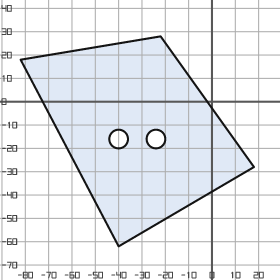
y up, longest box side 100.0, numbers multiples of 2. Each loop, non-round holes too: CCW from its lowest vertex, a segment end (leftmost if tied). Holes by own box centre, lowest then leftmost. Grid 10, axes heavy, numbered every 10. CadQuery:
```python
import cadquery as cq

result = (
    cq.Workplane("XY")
    .moveTo(-40.0, -62.0)
    .lineTo(18.0, -28.0)
    .lineTo(-22.0, 28.0)
    .lineTo(-82.0, 18.0)
    .close()
    .moveTo(-40.0, -16.0)
    .circle(4.0)
    .moveTo(-24.0, -16.0)
    .circle(4.0)
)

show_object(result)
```